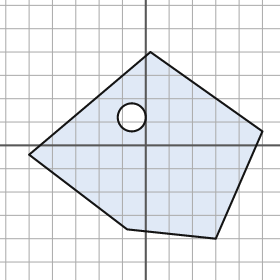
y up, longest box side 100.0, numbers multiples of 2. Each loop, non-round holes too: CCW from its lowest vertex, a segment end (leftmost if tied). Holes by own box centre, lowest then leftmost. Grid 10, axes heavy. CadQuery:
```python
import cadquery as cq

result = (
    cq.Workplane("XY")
    .moveTo(30.0, -40.0)
    .lineTo(50.0, 6.0)
    .lineTo(2.0, 40.0)
    .lineTo(-50.0, -4.0)
    .lineTo(-8.0, -36.0)
    .close()
    .moveTo(-6.0, 12.0)
    .circle(6.0)
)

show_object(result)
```